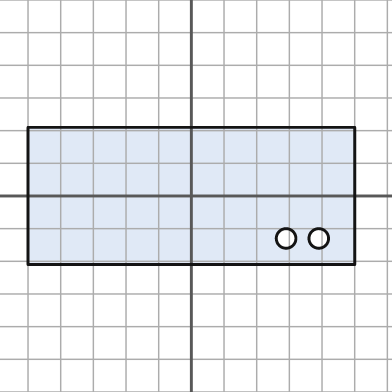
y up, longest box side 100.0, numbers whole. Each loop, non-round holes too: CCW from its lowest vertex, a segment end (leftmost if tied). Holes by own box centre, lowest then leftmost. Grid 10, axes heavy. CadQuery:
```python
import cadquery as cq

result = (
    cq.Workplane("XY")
    .moveTo(-50.0, -21.0)
    .lineTo(50.0, -21.0)
    .lineTo(50.0, 21.0)
    .lineTo(-50.0, 21.0)
    .close()
    .moveTo(29.0, -13.0)
    .circle(3.0)
    .moveTo(39.0, -13.0)
    .circle(3.0)
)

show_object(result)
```